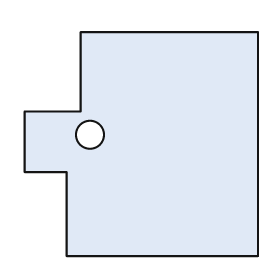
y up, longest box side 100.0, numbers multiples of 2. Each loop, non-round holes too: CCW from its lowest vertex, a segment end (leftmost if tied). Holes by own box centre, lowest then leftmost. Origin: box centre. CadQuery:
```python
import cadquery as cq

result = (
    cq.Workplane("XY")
    .moveTo(-32.0, -48.0)
    .lineTo(50.0, -48.0)
    .lineTo(50.0, 48.0)
    .lineTo(-26.0, 48.0)
    .lineTo(-26.0, 14.0)
    .lineTo(-50.0, 14.0)
    .lineTo(-50.0, -12.0)
    .lineTo(-32.0, -12.0)
    .close()
    .moveTo(-22.0, 4.0)
    .circle(6.0)
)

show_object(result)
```